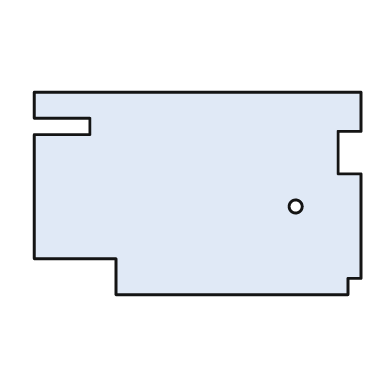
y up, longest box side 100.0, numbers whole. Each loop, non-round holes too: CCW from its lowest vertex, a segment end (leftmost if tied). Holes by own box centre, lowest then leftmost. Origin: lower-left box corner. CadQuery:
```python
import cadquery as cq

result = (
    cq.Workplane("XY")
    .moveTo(25.0, 0.0)
    .lineTo(96.0, 0.0)
    .lineTo(96.0, 5.0)
    .lineTo(100.0, 5.0)
    .lineTo(100.0, 37.0)
    .lineTo(93.0, 37.0)
    .lineTo(93.0, 50.0)
    .lineTo(100.0, 50.0)
    .lineTo(100.0, 62.0)
    .lineTo(0.0, 62.0)
    .lineTo(0.0, 54.0)
    .lineTo(17.0, 54.0)
    .lineTo(17.0, 49.0)
    .lineTo(0.0, 49.0)
    .lineTo(0.0, 11.0)
    .lineTo(25.0, 11.0)
    .close()
    .moveTo(80.0, 27.0)
    .circle(2.0)
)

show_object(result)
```